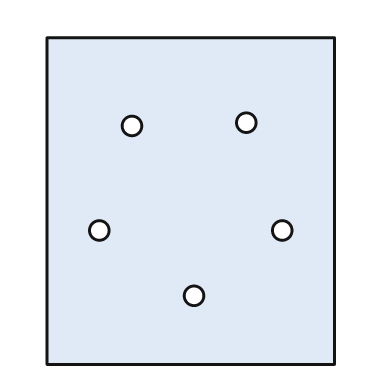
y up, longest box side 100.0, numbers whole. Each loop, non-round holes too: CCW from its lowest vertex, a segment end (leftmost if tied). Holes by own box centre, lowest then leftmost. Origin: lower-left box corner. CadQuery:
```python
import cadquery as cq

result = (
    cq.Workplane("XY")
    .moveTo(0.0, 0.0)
    .lineTo(88.0, 0.0)
    .lineTo(88.0, 100.0)
    .lineTo(0.0, 100.0)
    .close()
    .moveTo(45.0, 21.0)
    .circle(3.0)
    .moveTo(16.0, 41.0)
    .circle(3.0)
    .moveTo(72.0, 41.0)
    .circle(3.0)
    .moveTo(26.0, 73.0)
    .circle(3.0)
    .moveTo(61.0, 74.0)
    .circle(3.0)
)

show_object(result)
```